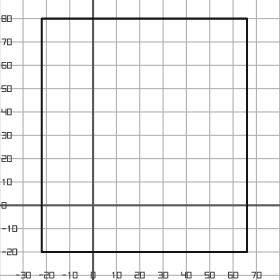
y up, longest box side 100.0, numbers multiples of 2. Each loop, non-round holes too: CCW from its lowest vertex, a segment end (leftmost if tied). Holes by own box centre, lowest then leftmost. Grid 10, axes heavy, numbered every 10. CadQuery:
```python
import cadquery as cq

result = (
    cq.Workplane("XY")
    .moveTo(-22.0, -20.0)
    .lineTo(66.0, -20.0)
    .lineTo(66.0, 80.0)
    .lineTo(-22.0, 80.0)
    .close()
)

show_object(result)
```